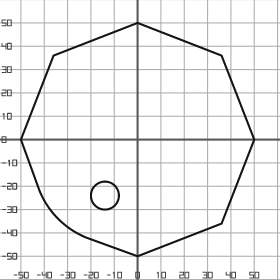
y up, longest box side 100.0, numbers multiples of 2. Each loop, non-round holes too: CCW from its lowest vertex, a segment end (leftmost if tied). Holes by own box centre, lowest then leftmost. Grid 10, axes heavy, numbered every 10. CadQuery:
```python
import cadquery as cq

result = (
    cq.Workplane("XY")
    .moveTo(0.0, -50.0)
    .lineTo(36.0, -36.0)
    .lineTo(50.0, 0.0)
    .lineTo(36.0, 36.0)
    .lineTo(0.0, 50.0)
    .lineTo(-36.0, 36.0)
    .lineTo(-50.0, 0.0)
    .lineTo(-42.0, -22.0)
    .threePointArc((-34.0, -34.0), (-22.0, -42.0))
    .close()
    .moveTo(-14.0, -24.0)
    .circle(6.0)
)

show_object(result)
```